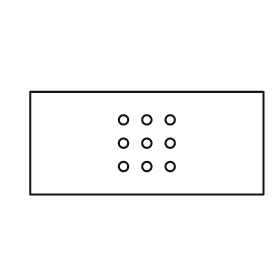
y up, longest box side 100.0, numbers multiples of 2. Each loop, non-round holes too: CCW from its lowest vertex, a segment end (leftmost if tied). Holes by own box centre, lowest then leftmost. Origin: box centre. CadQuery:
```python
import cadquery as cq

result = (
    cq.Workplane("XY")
    .moveTo(-50.0, -22.0)
    .lineTo(50.0, -22.0)
    .lineTo(50.0, 22.0)
    .lineTo(-50.0, 22.0)
    .close()
    .moveTo(-10.0, -10.0)
    .circle(2.0)
    .moveTo(0.0, -10.0)
    .circle(2.0)
    .moveTo(10.0, -10.0)
    .circle(2.0)
    .moveTo(-10.0, 0.0)
    .circle(2.0)
    .moveTo(0.0, 0.0)
    .circle(2.0)
    .moveTo(10.0, 0.0)
    .circle(2.0)
    .moveTo(-10.0, 10.0)
    .circle(2.0)
    .moveTo(0.0, 10.0)
    .circle(2.0)
    .moveTo(10.0, 10.0)
    .circle(2.0)
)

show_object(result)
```